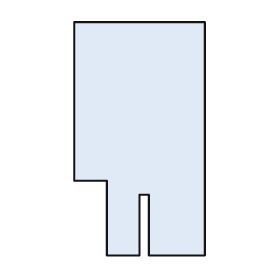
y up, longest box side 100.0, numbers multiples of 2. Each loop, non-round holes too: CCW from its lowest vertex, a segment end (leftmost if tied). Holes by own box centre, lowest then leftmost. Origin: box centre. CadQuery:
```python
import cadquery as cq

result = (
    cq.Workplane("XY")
    .moveTo(-14.0, -50.0)
    .lineTo(0.0, -50.0)
    .lineTo(0.0, -24.0)
    .lineTo(4.0, -24.0)
    .lineTo(4.0, -50.0)
    .lineTo(28.0, -50.0)
    .lineTo(28.0, 50.0)
    .lineTo(-28.0, 50.0)
    .lineTo(-28.0, -18.0)
    .lineTo(-14.0, -18.0)
    .close()
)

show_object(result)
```